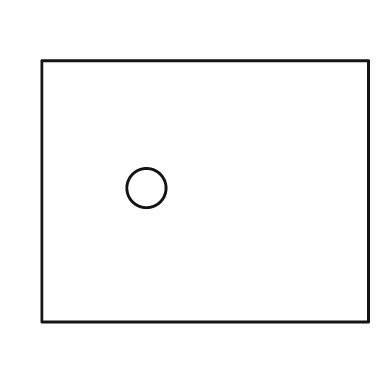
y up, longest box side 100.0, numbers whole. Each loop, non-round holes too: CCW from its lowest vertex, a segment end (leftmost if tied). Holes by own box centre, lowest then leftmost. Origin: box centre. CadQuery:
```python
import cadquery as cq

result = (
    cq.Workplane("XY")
    .moveTo(-50.0, -40.0)
    .lineTo(50.0, -40.0)
    .lineTo(50.0, 40.0)
    .lineTo(-50.0, 40.0)
    .close()
    .moveTo(-18.0, 1.0)
    .circle(6.0)
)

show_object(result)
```